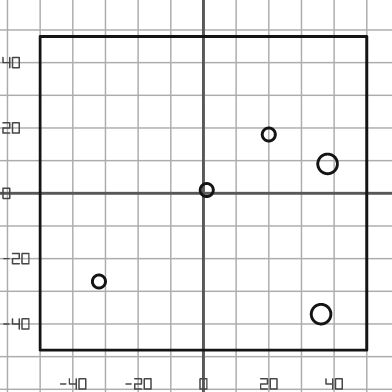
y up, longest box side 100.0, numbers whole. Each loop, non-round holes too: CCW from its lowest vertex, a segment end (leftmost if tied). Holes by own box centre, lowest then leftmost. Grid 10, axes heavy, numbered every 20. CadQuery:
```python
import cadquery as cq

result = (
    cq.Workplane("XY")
    .moveTo(-50.0, -48.0)
    .lineTo(50.0, -48.0)
    .lineTo(50.0, 48.0)
    .lineTo(-50.0, 48.0)
    .close()
    .moveTo(36.0, -37.0)
    .circle(3.0)
    .moveTo(-32.0, -27.0)
    .circle(2.0)
    .moveTo(1.0, 1.0)
    .circle(2.0)
    .moveTo(38.0, 9.0)
    .circle(3.0)
    .moveTo(20.0, 18.0)
    .circle(2.0)
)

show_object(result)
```